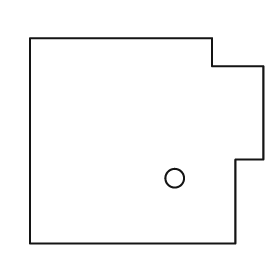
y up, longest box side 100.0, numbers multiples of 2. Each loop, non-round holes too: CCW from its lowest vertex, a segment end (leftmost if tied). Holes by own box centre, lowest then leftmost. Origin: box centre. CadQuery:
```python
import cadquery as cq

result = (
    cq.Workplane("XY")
    .moveTo(-50.0, -44.0)
    .lineTo(38.0, -44.0)
    .lineTo(38.0, -8.0)
    .lineTo(50.0, -8.0)
    .lineTo(50.0, 32.0)
    .lineTo(28.0, 32.0)
    .lineTo(28.0, 44.0)
    .lineTo(-50.0, 44.0)
    .close()
    .moveTo(12.0, -16.0)
    .circle(4.0)
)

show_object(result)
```